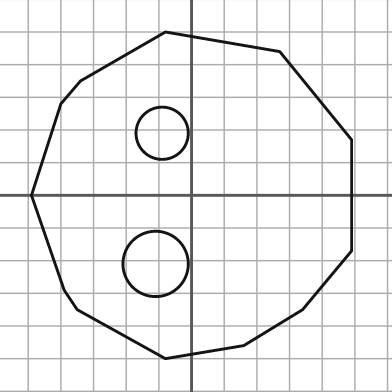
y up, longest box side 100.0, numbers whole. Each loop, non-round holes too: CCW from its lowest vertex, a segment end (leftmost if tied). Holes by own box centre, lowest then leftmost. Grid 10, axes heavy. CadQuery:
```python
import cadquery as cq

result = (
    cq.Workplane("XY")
    .moveTo(-8.0, -50.0)
    .lineTo(16.0, -46.0)
    .lineTo(34.0, -35.0)
    .lineTo(49.0, -17.0)
    .lineTo(49.0, 17.0)
    .lineTo(27.0, 44.0)
    .lineTo(-8.0, 50.0)
    .lineTo(-34.0, 35.0)
    .lineTo(-40.0, 28.0)
    .lineTo(-49.0, 0.0)
    .lineTo(-39.0, -29.0)
    .lineTo(-35.0, -35.0)
    .close()
    .moveTo(-11.0, -21.0)
    .circle(10.0)
    .moveTo(-9.0, 19.0)
    .circle(8.0)
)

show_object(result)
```